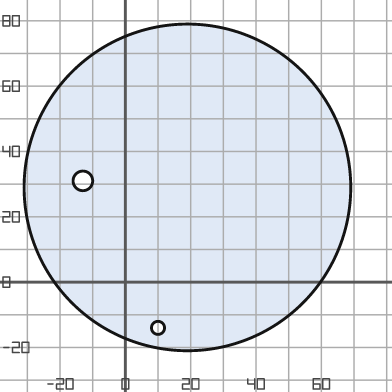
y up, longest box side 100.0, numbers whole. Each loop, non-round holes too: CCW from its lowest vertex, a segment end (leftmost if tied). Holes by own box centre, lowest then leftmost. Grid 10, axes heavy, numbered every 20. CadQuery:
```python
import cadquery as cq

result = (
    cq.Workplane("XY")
    .moveTo(19.0, 29.0)
    .circle(50.0)
    .moveTo(10.0, -14.0)
    .circle(2.0)
    .moveTo(-13.0, 31.0)
    .circle(3.0)
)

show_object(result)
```